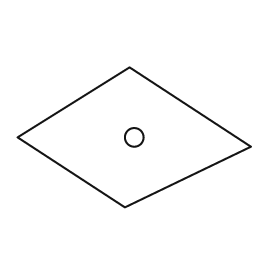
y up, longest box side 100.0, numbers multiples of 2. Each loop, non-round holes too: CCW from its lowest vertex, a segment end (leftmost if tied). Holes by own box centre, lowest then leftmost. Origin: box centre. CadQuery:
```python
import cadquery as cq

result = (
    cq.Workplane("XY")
    .moveTo(-4.0, -30.0)
    .lineTo(50.0, -4.0)
    .lineTo(-2.0, 30.0)
    .lineTo(-50.0, 0.0)
    .close()
    .moveTo(0.0, 0.0)
    .circle(4.0)
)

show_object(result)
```